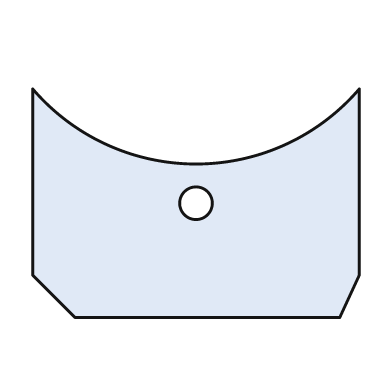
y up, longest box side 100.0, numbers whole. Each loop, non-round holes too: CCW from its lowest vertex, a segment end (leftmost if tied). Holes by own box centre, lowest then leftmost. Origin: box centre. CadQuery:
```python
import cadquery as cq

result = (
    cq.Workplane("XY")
    .moveTo(-37.0, -35.0)
    .lineTo(44.0, -35.0)
    .lineTo(50.0, -22.0)
    .lineTo(50.0, 35.0)
    .threePointArc((0.0, 12.0), (-50.0, 35.0))
    .lineTo(-50.0, -22.0)
    .close()
    .moveTo(0.0, 0.0)
    .circle(5.0)
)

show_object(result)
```